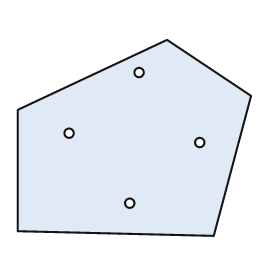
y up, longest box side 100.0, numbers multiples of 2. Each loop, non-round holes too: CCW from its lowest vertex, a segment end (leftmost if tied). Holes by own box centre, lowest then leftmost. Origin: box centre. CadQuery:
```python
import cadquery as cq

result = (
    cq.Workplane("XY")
    .moveTo(34.0, -42.0)
    .lineTo(50.0, 18.0)
    .lineTo(14.0, 42.0)
    .lineTo(-50.0, 12.0)
    .lineTo(-50.0, -40.0)
    .close()
    .moveTo(-2.0, -28.0)
    .circle(2.0)
    .moveTo(28.0, -2.0)
    .circle(2.0)
    .moveTo(-28.0, 2.0)
    .circle(2.0)
    .moveTo(2.0, 28.0)
    .circle(2.0)
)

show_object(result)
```